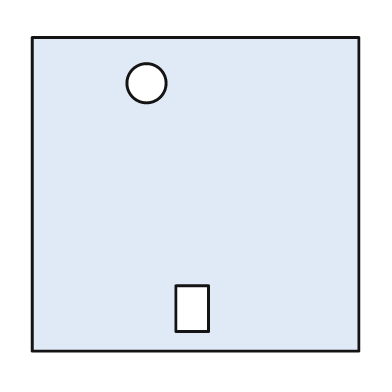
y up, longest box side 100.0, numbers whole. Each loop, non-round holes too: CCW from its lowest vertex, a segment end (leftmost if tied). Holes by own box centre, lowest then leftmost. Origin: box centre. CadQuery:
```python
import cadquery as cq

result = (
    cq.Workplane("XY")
    .moveTo(-50.0, -48.0)
    .lineTo(50.0, -48.0)
    .lineTo(50.0, 48.0)
    .lineTo(-50.0, 48.0)
    .close()
    .moveTo(-6.0, -42.0)
    .lineTo(4.0, -42.0)
    .lineTo(4.0, -28.0)
    .lineTo(-6.0, -28.0)
    .close()
    .moveTo(-15.0, 34.0)
    .circle(6.0)
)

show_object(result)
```